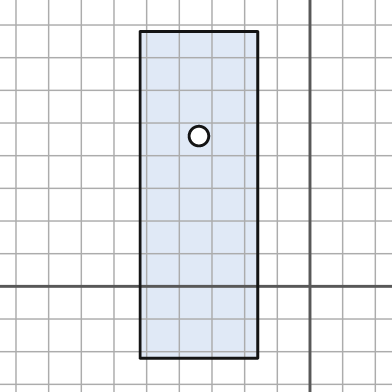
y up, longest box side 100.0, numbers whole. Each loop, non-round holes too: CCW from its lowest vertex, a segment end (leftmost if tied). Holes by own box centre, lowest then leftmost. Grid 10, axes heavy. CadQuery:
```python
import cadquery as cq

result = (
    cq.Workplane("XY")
    .moveTo(-52.0, -22.0)
    .lineTo(-16.0, -22.0)
    .lineTo(-16.0, 78.0)
    .lineTo(-52.0, 78.0)
    .close()
    .moveTo(-34.0, 46.0)
    .circle(3.0)
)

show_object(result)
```